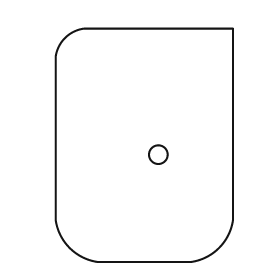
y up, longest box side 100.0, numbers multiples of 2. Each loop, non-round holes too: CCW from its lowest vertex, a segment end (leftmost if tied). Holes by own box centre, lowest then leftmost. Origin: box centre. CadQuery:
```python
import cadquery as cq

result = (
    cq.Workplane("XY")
    .moveTo(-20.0, -50.0)
    .lineTo(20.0, -50.0)
    .threePointArc((32.0, -44.0), (38.0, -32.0))
    .lineTo(38.0, 50.0)
    .lineTo(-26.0, 50.0)
    .threePointArc((-34.0, 46.0), (-38.0, 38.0))
    .lineTo(-38.0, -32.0)
    .threePointArc((-32.0, -44.0), (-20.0, -50.0))
    .close()
    .moveTo(6.0, -4.0)
    .circle(4.0)
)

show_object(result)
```